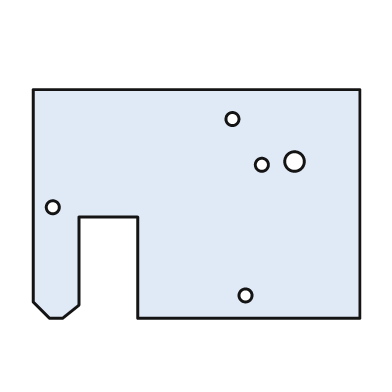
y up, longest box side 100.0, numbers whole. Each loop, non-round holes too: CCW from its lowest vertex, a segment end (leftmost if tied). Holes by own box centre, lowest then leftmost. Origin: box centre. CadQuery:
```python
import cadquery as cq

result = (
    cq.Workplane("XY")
    .moveTo(-45.0, -35.0)
    .lineTo(-41.0, -35.0)
    .lineTo(-36.0, -31.0)
    .lineTo(-36.0, -4.0)
    .lineTo(-18.0, -4.0)
    .lineTo(-18.0, -35.0)
    .lineTo(50.0, -35.0)
    .lineTo(50.0, 35.0)
    .lineTo(-50.0, 35.0)
    .lineTo(-50.0, -30.0)
    .close()
    .moveTo(15.0, -28.0)
    .circle(2.0)
    .moveTo(-44.0, -1.0)
    .circle(2.0)
    .moveTo(20.0, 12.0)
    .circle(2.0)
    .moveTo(30.0, 13.0)
    .circle(3.0)
    .moveTo(11.0, 26.0)
    .circle(2.0)
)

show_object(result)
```